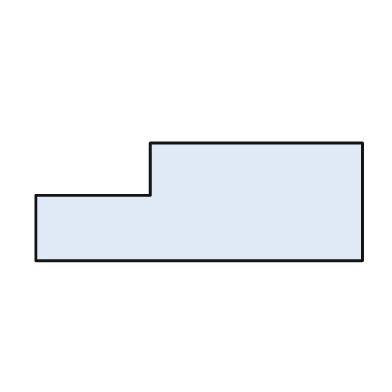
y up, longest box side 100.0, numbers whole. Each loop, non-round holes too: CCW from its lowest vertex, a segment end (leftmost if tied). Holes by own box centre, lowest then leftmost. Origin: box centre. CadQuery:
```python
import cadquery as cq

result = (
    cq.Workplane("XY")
    .moveTo(-50.0, -18.0)
    .lineTo(50.0, -18.0)
    .lineTo(50.0, 18.0)
    .lineTo(-15.0, 18.0)
    .lineTo(-15.0, 2.0)
    .lineTo(-50.0, 2.0)
    .close()
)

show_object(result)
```